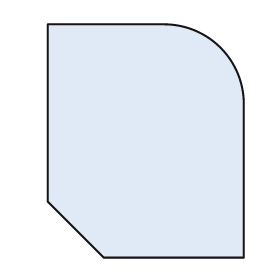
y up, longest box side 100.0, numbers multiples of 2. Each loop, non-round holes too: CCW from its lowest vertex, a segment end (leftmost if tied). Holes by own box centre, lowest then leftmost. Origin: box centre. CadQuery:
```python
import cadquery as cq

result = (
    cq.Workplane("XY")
    .moveTo(-18.0, -50.0)
    .lineTo(42.0, -50.0)
    .lineTo(42.0, 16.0)
    .threePointArc((32.0, 40.0), (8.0, 50.0))
    .lineTo(-42.0, 50.0)
    .lineTo(-42.0, -26.0)
    .close()
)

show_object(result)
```